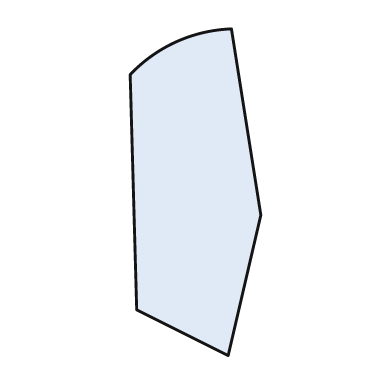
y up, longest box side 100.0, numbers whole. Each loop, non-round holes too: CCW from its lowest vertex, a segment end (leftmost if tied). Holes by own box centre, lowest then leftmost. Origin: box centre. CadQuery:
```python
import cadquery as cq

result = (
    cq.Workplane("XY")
    .moveTo(10.0, -50.0)
    .lineTo(20.0, -7.0)
    .lineTo(11.0, 50.0)
    .threePointArc((-6.0, 46.0), (-20.0, 36.0))
    .lineTo(-18.0, -36.0)
    .close()
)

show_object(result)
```